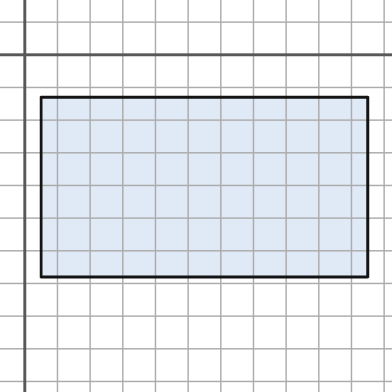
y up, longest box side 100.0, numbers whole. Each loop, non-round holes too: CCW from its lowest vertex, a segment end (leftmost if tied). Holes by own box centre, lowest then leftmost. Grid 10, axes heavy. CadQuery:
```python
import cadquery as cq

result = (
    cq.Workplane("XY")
    .moveTo(5.0, -68.0)
    .lineTo(105.0, -68.0)
    .lineTo(105.0, -13.0)
    .lineTo(5.0, -13.0)
    .close()
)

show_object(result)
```